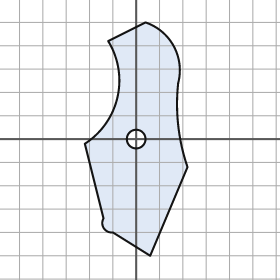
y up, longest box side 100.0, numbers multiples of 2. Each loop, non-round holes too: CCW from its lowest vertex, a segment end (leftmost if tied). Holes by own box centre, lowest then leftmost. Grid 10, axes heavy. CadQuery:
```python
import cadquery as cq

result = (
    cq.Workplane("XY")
    .moveTo(6.0, -50.0)
    .lineTo(22.0, -12.0)
    .threePointArc((18.0, 6.0), (18.0, 24.0))
    .threePointArc((16.0, 40.0), (4.0, 50.0))
    .lineTo(-12.0, 42.0)
    .threePointArc((-8.0, 18.0), (-22.0, -2.0))
    .lineTo(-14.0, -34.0)
    .threePointArc((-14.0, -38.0), (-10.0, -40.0))
    .close()
    .moveTo(0.0, 0.0)
    .circle(4.0)
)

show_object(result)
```